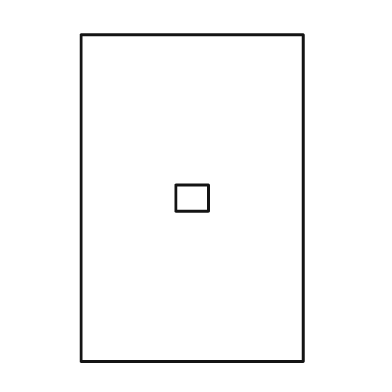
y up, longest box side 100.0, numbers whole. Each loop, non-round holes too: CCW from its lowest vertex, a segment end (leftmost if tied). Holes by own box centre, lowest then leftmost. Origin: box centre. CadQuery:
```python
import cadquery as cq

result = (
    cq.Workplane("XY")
    .moveTo(-34.0, -50.0)
    .lineTo(34.0, -50.0)
    .lineTo(34.0, 50.0)
    .lineTo(-34.0, 50.0)
    .close()
    .moveTo(-5.0, -4.0)
    .lineTo(5.0, -4.0)
    .lineTo(5.0, 4.0)
    .lineTo(-5.0, 4.0)
    .close()
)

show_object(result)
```